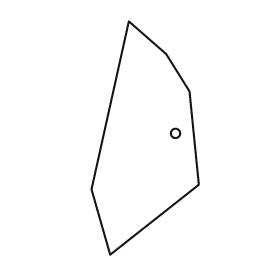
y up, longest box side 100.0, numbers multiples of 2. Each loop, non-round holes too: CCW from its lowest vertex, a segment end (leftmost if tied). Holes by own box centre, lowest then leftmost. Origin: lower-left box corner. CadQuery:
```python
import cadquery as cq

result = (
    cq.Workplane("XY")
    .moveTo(8.0, 0.0)
    .lineTo(46.0, 30.0)
    .lineTo(42.0, 70.0)
    .lineTo(32.0, 86.0)
    .lineTo(16.0, 100.0)
    .lineTo(0.0, 28.0)
    .close()
    .moveTo(36.0, 52.0)
    .circle(2.0)
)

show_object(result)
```